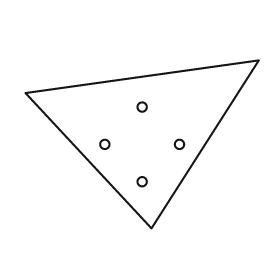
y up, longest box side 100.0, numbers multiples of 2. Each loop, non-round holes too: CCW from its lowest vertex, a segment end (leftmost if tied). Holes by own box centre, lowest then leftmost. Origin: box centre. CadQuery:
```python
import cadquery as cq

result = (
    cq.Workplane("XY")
    .moveTo(4.0, -36.0)
    .lineTo(50.0, 36.0)
    .lineTo(-50.0, 22.0)
    .close()
    .moveTo(0.0, -16.0)
    .circle(2.0)
    .moveTo(-16.0, 0.0)
    .circle(2.0)
    .moveTo(16.0, 0.0)
    .circle(2.0)
    .moveTo(0.0, 16.0)
    .circle(2.0)
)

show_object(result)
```